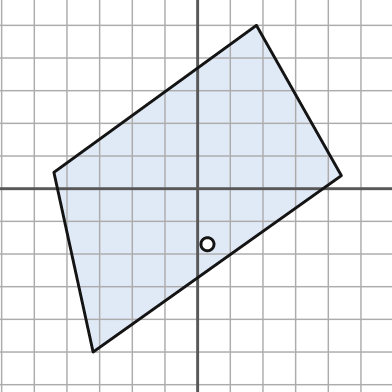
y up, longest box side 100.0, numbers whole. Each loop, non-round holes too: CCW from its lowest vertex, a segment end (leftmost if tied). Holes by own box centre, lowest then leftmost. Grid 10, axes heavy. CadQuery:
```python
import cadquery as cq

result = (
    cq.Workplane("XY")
    .moveTo(-32.0, -50.0)
    .lineTo(44.0, 4.0)
    .lineTo(18.0, 50.0)
    .lineTo(-44.0, 5.0)
    .close()
    .moveTo(3.0, -17.0)
    .circle(2.0)
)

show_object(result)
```